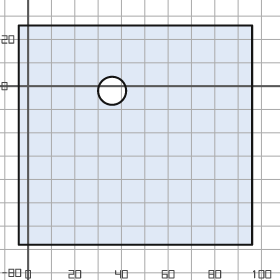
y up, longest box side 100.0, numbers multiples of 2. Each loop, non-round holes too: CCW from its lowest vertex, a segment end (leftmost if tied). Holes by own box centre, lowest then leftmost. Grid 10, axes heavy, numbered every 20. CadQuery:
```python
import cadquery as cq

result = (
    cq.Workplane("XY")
    .moveTo(-4.0, -68.0)
    .lineTo(96.0, -68.0)
    .lineTo(96.0, 26.0)
    .lineTo(-4.0, 26.0)
    .close()
    .moveTo(36.0, -2.0)
    .circle(6.0)
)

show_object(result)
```